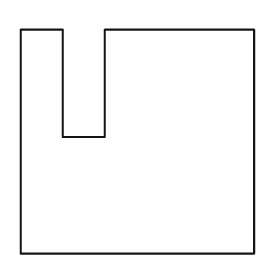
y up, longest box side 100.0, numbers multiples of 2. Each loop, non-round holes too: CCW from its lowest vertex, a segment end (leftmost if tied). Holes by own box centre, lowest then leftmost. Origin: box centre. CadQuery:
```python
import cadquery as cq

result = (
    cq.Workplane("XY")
    .moveTo(-50.0, -48.0)
    .lineTo(50.0, -48.0)
    .lineTo(50.0, 48.0)
    .lineTo(-14.0, 48.0)
    .lineTo(-14.0, 2.0)
    .lineTo(-32.0, 2.0)
    .lineTo(-32.0, 48.0)
    .lineTo(-50.0, 48.0)
    .close()
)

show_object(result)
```